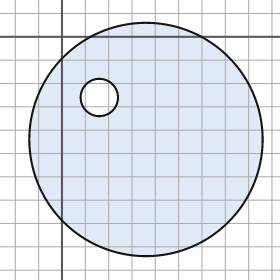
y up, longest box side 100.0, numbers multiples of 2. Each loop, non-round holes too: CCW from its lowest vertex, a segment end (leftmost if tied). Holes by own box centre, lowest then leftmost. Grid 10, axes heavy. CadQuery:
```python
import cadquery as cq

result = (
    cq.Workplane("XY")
    .moveTo(36.0, -44.0)
    .circle(50.0)
    .moveTo(16.0, -26.0)
    .circle(8.0)
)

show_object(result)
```